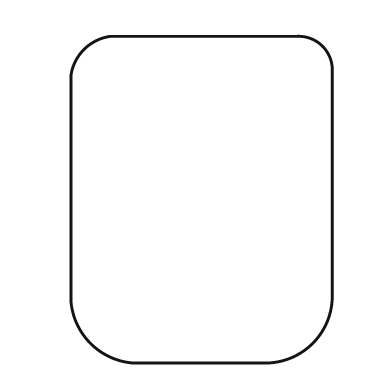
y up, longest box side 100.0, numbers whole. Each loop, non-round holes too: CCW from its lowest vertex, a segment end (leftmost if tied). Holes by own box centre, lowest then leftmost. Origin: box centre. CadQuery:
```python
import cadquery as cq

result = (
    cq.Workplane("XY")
    .moveTo(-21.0, -50.0)
    .lineTo(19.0, -50.0)
    .threePointArc((34.0, -44.0), (40.0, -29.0))
    .lineTo(40.0, 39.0)
    .threePointArc((37.0, 47.0), (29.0, 50.0))
    .lineTo(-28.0, 50.0)
    .threePointArc((-36.0, 46.0), (-40.0, 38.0))
    .lineTo(-40.0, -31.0)
    .threePointArc((-34.0, -44.0), (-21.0, -50.0))
    .close()
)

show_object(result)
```